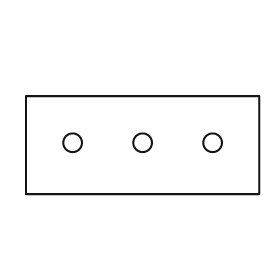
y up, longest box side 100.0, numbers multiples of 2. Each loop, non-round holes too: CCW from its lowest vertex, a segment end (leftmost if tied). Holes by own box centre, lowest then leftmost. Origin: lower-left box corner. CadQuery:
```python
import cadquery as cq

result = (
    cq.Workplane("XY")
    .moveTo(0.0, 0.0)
    .lineTo(100.0, 0.0)
    .lineTo(100.0, 42.0)
    .lineTo(0.0, 42.0)
    .close()
    .moveTo(20.0, 22.0)
    .circle(4.0)
    .moveTo(50.0, 22.0)
    .circle(4.0)
    .moveTo(80.0, 22.0)
    .circle(4.0)
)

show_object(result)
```